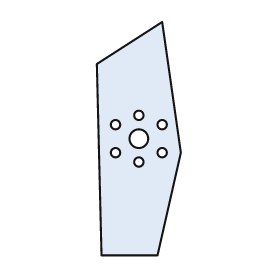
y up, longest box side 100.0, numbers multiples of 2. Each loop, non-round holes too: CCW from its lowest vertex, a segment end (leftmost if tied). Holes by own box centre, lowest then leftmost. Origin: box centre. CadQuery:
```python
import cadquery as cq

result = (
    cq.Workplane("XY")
    .moveTo(-16.0, -50.0)
    .lineTo(8.0, -50.0)
    .lineTo(18.0, -6.0)
    .lineTo(10.0, 50.0)
    .lineTo(-18.0, 32.0)
    .close()
    .moveTo(0.0, -10.0)
    .circle(2.0)
    .moveTo(-10.0, -6.0)
    .circle(2.0)
    .moveTo(10.0, -6.0)
    .circle(2.0)
    .moveTo(0.0, 0.0)
    .circle(4.0)
    .moveTo(-10.0, 6.0)
    .circle(2.0)
    .moveTo(10.0, 6.0)
    .circle(2.0)
    .moveTo(0.0, 10.0)
    .circle(2.0)
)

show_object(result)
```